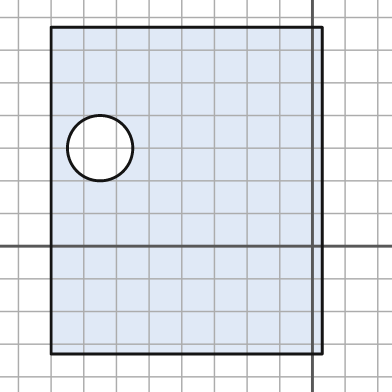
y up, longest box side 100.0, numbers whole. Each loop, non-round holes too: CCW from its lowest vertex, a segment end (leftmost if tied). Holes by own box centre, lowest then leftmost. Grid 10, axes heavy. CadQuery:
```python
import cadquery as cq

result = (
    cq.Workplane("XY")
    .moveTo(-80.0, -33.0)
    .lineTo(3.0, -33.0)
    .lineTo(3.0, 67.0)
    .lineTo(-80.0, 67.0)
    .close()
    .moveTo(-65.0, 30.0)
    .circle(10.0)
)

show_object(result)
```